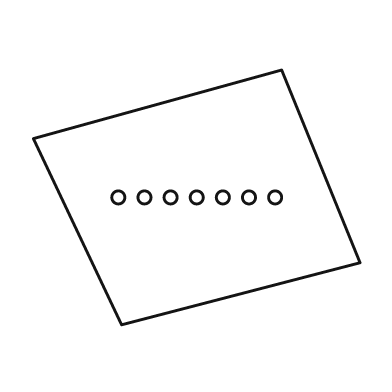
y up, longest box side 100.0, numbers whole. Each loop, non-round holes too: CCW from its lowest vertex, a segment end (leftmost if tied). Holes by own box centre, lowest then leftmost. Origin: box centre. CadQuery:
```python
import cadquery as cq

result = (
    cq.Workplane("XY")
    .moveTo(-23.0, -39.0)
    .lineTo(50.0, -20.0)
    .lineTo(26.0, 39.0)
    .lineTo(-50.0, 18.0)
    .close()
    .moveTo(-24.0, 0.0)
    .circle(2.0)
    .moveTo(-16.0, 0.0)
    .circle(2.0)
    .moveTo(-8.0, 0.0)
    .circle(2.0)
    .moveTo(0.0, 0.0)
    .circle(2.0)
    .moveTo(8.0, 0.0)
    .circle(2.0)
    .moveTo(16.0, 0.0)
    .circle(2.0)
    .moveTo(24.0, 0.0)
    .circle(2.0)
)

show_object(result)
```